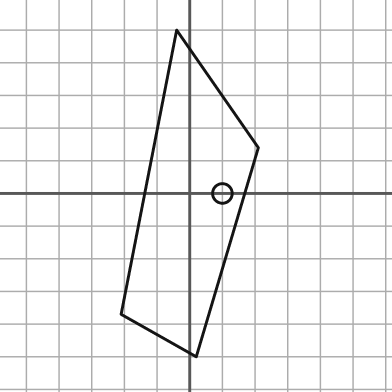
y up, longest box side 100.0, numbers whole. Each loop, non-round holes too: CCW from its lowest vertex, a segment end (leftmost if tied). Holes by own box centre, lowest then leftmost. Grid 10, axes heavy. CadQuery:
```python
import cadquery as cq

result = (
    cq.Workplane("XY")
    .moveTo(2.0, -50.0)
    .lineTo(21.0, 14.0)
    .lineTo(-4.0, 50.0)
    .lineTo(-21.0, -37.0)
    .close()
    .moveTo(10.0, 0.0)
    .circle(3.0)
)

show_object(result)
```